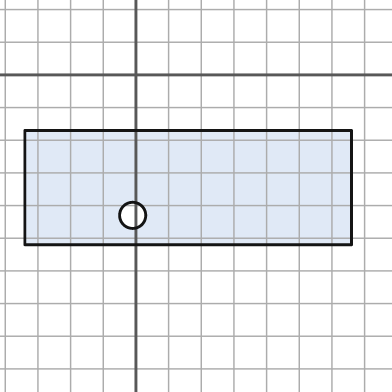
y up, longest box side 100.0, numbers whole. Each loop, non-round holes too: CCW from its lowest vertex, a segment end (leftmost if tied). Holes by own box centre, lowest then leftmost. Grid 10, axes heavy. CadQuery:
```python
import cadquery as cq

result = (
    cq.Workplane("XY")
    .moveTo(-34.0, -52.0)
    .lineTo(66.0, -52.0)
    .lineTo(66.0, -17.0)
    .lineTo(-34.0, -17.0)
    .close()
    .moveTo(-1.0, -43.0)
    .circle(4.0)
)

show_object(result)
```